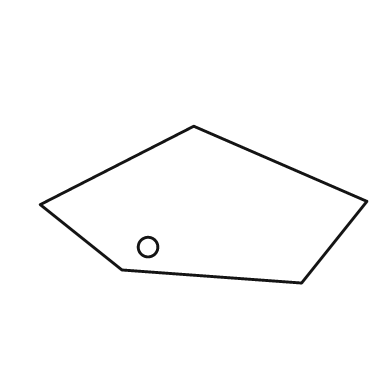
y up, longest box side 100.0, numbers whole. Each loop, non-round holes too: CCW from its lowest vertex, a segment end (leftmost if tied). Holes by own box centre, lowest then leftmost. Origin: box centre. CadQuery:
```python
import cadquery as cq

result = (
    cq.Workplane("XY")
    .moveTo(30.0, -24.0)
    .lineTo(50.0, 1.0)
    .lineTo(-3.0, 24.0)
    .lineTo(-50.0, 0.0)
    .lineTo(-25.0, -20.0)
    .close()
    .moveTo(-17.0, -13.0)
    .circle(3.0)
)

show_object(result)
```